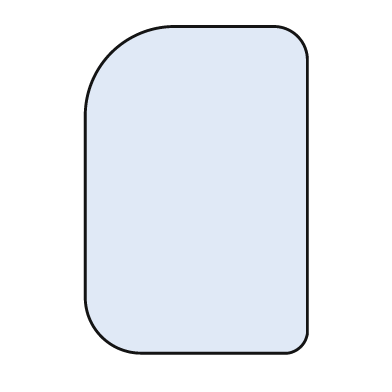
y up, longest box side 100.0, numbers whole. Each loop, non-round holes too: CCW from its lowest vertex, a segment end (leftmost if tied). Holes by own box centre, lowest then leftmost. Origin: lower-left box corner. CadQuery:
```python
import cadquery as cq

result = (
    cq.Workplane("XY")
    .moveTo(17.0, 0.0)
    .lineTo(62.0, 0.0)
    .threePointArc((66.0, 2.0), (68.0, 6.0))
    .lineTo(68.0, 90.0)
    .threePointArc((65.0, 97.0), (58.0, 100.0))
    .lineTo(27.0, 100.0)
    .threePointArc((8.0, 92.0), (0.0, 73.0))
    .lineTo(0.0, 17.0)
    .threePointArc((5.0, 5.0), (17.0, 0.0))
    .close()
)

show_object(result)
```